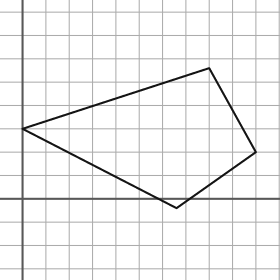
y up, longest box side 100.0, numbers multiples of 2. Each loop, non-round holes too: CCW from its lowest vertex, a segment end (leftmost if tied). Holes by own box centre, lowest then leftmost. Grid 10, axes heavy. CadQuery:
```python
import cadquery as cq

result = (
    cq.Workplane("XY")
    .moveTo(66.0, -4.0)
    .lineTo(100.0, 20.0)
    .lineTo(80.0, 56.0)
    .lineTo(0.0, 30.0)
    .close()
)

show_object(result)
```